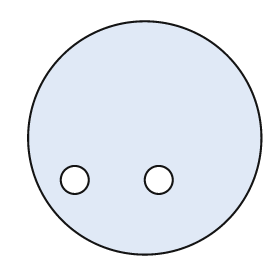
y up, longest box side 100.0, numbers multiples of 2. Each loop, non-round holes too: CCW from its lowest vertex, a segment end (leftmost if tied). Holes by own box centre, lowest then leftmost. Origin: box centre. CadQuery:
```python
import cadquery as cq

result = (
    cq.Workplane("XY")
    .moveTo(0.0, 0.0)
    .circle(50.0)
    .moveTo(-30.0, -18.0)
    .circle(6.0)
    .moveTo(6.0, -18.0)
    .circle(6.0)
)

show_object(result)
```